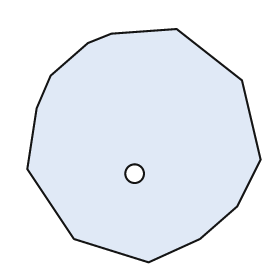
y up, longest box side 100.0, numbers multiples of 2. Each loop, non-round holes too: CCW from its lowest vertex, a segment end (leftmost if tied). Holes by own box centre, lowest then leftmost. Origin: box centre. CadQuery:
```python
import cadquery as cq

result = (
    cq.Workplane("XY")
    .moveTo(2.0, -50.0)
    .lineTo(24.0, -40.0)
    .lineTo(40.0, -26.0)
    .lineTo(50.0, -6.0)
    .lineTo(42.0, 28.0)
    .lineTo(14.0, 50.0)
    .lineTo(-14.0, 48.0)
    .lineTo(-24.0, 44.0)
    .lineTo(-40.0, 30.0)
    .lineTo(-46.0, 16.0)
    .lineTo(-50.0, -10.0)
    .lineTo(-30.0, -40.0)
    .close()
    .moveTo(-4.0, -12.0)
    .circle(4.0)
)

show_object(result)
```